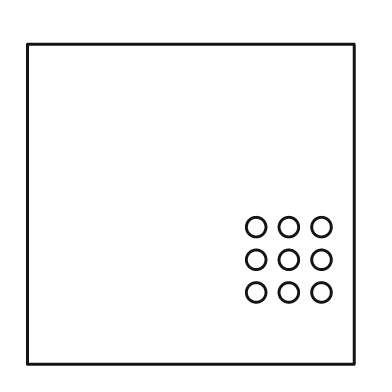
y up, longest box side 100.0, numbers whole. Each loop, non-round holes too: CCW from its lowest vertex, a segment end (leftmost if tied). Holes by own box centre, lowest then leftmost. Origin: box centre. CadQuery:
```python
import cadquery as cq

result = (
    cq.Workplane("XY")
    .moveTo(-50.0, -49.0)
    .lineTo(50.0, -49.0)
    .lineTo(50.0, 49.0)
    .lineTo(-50.0, 49.0)
    .close()
    .moveTo(20.0, -27.0)
    .circle(3.0)
    .moveTo(30.0, -27.0)
    .circle(3.0)
    .moveTo(40.0, -27.0)
    .circle(3.0)
    .moveTo(20.0, -17.0)
    .circle(3.0)
    .moveTo(30.0, -17.0)
    .circle(3.0)
    .moveTo(40.0, -17.0)
    .circle(3.0)
    .moveTo(20.0, -7.0)
    .circle(3.0)
    .moveTo(30.0, -7.0)
    .circle(3.0)
    .moveTo(40.0, -7.0)
    .circle(3.0)
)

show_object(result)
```